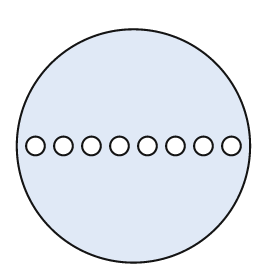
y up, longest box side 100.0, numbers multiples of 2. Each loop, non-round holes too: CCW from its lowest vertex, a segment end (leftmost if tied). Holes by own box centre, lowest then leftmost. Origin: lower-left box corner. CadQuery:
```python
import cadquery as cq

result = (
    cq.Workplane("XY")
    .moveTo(50.0, 50.0)
    .circle(50.0)
    .moveTo(8.0, 50.0)
    .circle(4.0)
    .moveTo(20.0, 50.0)
    .circle(4.0)
    .moveTo(32.0, 50.0)
    .circle(4.0)
    .moveTo(44.0, 50.0)
    .circle(4.0)
    .moveTo(56.0, 50.0)
    .circle(4.0)
    .moveTo(68.0, 50.0)
    .circle(4.0)
    .moveTo(80.0, 50.0)
    .circle(4.0)
    .moveTo(92.0, 50.0)
    .circle(4.0)
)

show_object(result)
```